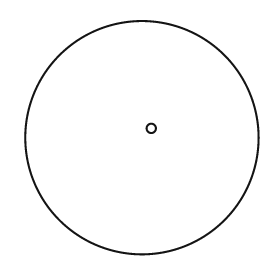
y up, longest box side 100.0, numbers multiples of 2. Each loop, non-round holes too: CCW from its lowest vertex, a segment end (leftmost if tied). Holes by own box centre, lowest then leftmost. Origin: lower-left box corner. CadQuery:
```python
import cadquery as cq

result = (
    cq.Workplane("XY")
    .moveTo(50.0, 50.0)
    .circle(50.0)
    .moveTo(54.0, 54.0)
    .circle(2.0)
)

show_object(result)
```